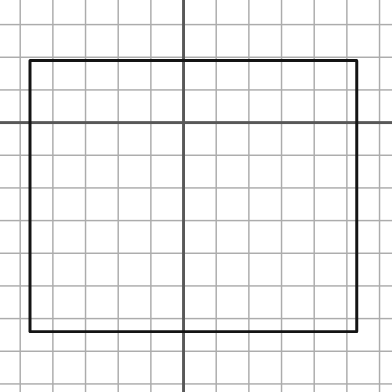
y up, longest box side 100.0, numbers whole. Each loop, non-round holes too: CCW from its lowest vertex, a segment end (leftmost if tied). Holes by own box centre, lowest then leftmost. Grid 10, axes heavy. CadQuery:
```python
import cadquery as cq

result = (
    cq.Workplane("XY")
    .moveTo(-47.0, -64.0)
    .lineTo(53.0, -64.0)
    .lineTo(53.0, 19.0)
    .lineTo(-47.0, 19.0)
    .close()
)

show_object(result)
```